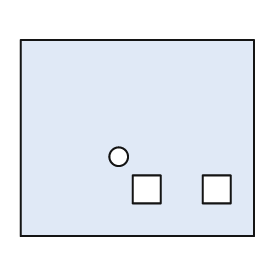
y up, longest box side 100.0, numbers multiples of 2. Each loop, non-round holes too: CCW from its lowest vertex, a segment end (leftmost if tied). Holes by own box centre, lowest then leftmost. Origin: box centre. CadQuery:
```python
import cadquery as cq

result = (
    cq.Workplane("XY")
    .moveTo(-50.0, -42.0)
    .lineTo(50.0, -42.0)
    .lineTo(50.0, 42.0)
    .lineTo(-50.0, 42.0)
    .close()
    .moveTo(-2.0, -28.0)
    .lineTo(10.0, -28.0)
    .lineTo(10.0, -16.0)
    .lineTo(-2.0, -16.0)
    .close()
    .moveTo(28.0, -28.0)
    .lineTo(40.0, -28.0)
    .lineTo(40.0, -16.0)
    .lineTo(28.0, -16.0)
    .close()
    .moveTo(-8.0, -8.0)
    .circle(4.0)
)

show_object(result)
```